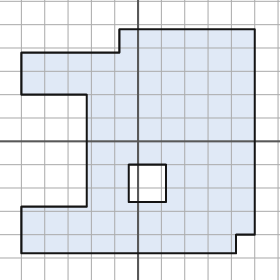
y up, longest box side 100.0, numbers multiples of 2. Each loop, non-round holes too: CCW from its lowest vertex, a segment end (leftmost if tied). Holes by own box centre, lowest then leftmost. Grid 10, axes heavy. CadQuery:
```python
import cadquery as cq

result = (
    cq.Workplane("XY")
    .moveTo(-50.0, -48.0)
    .lineTo(42.0, -48.0)
    .lineTo(42.0, -40.0)
    .lineTo(50.0, -40.0)
    .lineTo(50.0, 48.0)
    .lineTo(-8.0, 48.0)
    .lineTo(-8.0, 38.0)
    .lineTo(-50.0, 38.0)
    .lineTo(-50.0, 20.0)
    .lineTo(-22.0, 20.0)
    .lineTo(-22.0, -28.0)
    .lineTo(-50.0, -28.0)
    .close()
    .moveTo(-4.0, -26.0)
    .lineTo(12.0, -26.0)
    .lineTo(12.0, -10.0)
    .lineTo(-4.0, -10.0)
    .close()
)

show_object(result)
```